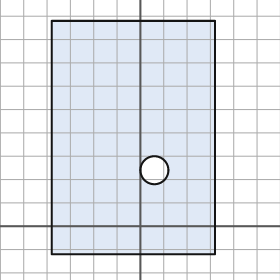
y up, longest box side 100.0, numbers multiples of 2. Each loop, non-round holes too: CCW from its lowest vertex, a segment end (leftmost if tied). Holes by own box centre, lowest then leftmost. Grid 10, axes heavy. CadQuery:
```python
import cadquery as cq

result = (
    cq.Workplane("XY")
    .moveTo(-38.0, -12.0)
    .lineTo(32.0, -12.0)
    .lineTo(32.0, 88.0)
    .lineTo(-38.0, 88.0)
    .close()
    .moveTo(6.0, 24.0)
    .circle(6.0)
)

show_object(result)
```